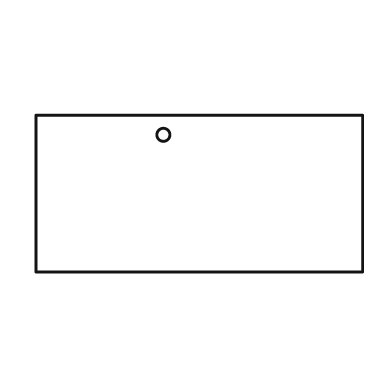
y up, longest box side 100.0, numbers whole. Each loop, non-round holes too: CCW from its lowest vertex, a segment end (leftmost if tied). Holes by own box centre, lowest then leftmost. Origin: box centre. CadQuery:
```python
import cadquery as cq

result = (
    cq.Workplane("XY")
    .moveTo(-50.0, -24.0)
    .lineTo(50.0, -24.0)
    .lineTo(50.0, 24.0)
    .lineTo(-50.0, 24.0)
    .close()
    .moveTo(-11.0, 18.0)
    .circle(2.0)
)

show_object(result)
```